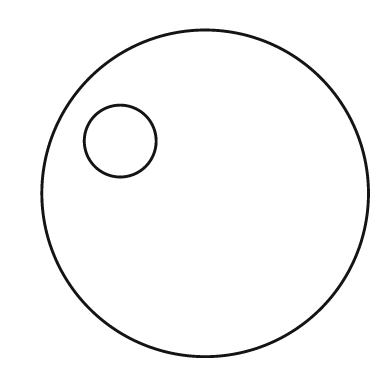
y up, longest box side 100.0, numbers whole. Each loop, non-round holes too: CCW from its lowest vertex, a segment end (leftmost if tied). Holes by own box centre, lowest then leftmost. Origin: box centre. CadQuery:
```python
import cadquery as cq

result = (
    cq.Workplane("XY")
    .moveTo(0.0, 0.0)
    .circle(50.0)
    .moveTo(-26.0, 16.0)
    .circle(11.0)
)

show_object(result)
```